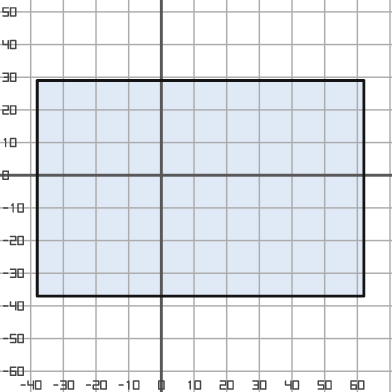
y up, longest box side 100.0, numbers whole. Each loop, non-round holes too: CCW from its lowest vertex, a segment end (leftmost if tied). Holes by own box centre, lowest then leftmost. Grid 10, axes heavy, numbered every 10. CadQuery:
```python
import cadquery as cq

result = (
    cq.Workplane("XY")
    .moveTo(-38.0, -37.0)
    .lineTo(62.0, -37.0)
    .lineTo(62.0, 29.0)
    .lineTo(-38.0, 29.0)
    .close()
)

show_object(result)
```